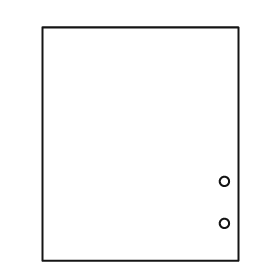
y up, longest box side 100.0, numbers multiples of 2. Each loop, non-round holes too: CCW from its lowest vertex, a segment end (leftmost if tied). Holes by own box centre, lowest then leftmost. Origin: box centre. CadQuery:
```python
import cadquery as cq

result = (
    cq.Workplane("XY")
    .moveTo(-42.0, -50.0)
    .lineTo(42.0, -50.0)
    .lineTo(42.0, 50.0)
    .lineTo(-42.0, 50.0)
    .close()
    .moveTo(36.0, -34.0)
    .circle(2.0)
    .moveTo(36.0, -16.0)
    .circle(2.0)
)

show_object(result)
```